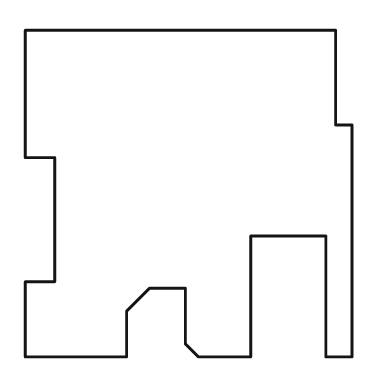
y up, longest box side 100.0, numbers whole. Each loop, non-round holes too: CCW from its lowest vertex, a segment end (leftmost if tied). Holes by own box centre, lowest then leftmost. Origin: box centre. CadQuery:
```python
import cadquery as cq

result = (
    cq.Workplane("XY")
    .moveTo(-50.0, -50.0)
    .lineTo(-19.0, -50.0)
    .lineTo(-19.0, -36.0)
    .lineTo(-12.0, -29.0)
    .lineTo(-1.0, -29.0)
    .lineTo(-1.0, -46.0)
    .lineTo(3.0, -50.0)
    .lineTo(19.0, -50.0)
    .lineTo(19.0, -13.0)
    .lineTo(42.0, -13.0)
    .lineTo(42.0, -50.0)
    .lineTo(50.0, -50.0)
    .lineTo(50.0, 21.0)
    .lineTo(45.0, 21.0)
    .lineTo(45.0, 50.0)
    .lineTo(-50.0, 50.0)
    .lineTo(-50.0, 11.0)
    .lineTo(-41.0, 11.0)
    .lineTo(-41.0, -27.0)
    .lineTo(-50.0, -27.0)
    .close()
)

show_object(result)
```